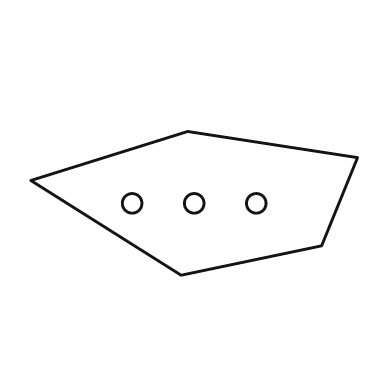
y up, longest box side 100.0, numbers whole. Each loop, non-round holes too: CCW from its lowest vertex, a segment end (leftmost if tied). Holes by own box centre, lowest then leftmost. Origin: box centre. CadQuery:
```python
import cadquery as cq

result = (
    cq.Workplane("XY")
    .moveTo(-4.0, -22.0)
    .lineTo(39.0, -13.0)
    .lineTo(50.0, 14.0)
    .lineTo(-2.0, 22.0)
    .lineTo(-50.0, 7.0)
    .close()
    .moveTo(-19.0, 0.0)
    .circle(3.0)
    .moveTo(0.0, 0.0)
    .circle(3.0)
    .moveTo(19.0, 0.0)
    .circle(3.0)
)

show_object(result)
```